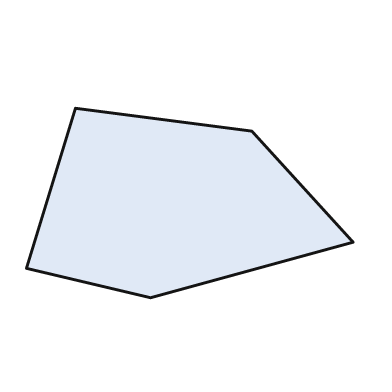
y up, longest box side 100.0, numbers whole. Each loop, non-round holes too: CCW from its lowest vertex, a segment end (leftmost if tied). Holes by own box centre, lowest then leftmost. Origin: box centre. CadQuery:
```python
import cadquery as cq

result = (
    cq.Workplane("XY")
    .moveTo(-12.0, -29.0)
    .lineTo(50.0, -12.0)
    .lineTo(19.0, 22.0)
    .lineTo(-35.0, 29.0)
    .lineTo(-50.0, -20.0)
    .close()
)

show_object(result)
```